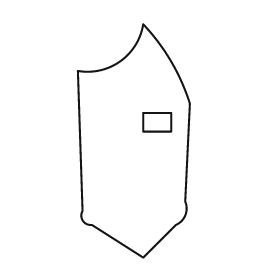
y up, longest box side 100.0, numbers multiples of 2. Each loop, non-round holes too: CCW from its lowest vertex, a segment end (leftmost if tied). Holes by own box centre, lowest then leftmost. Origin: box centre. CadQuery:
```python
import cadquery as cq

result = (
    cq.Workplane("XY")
    .moveTo(4.0, -50.0)
    .lineTo(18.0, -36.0)
    .threePointArc((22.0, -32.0), (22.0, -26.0))
    .lineTo(24.0, 16.0)
    .threePointArc((16.0, 34.0), (4.0, 50.0))
    .threePointArc((-6.0, 34.0), (-24.0, 30.0))
    .lineTo(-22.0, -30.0)
    .threePointArc((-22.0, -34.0), (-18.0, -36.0))
    .close()
    .moveTo(4.0, 4.0)
    .lineTo(16.0, 4.0)
    .lineTo(16.0, 12.0)
    .lineTo(4.0, 12.0)
    .close()
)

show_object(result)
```